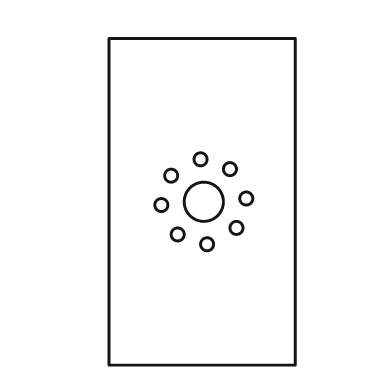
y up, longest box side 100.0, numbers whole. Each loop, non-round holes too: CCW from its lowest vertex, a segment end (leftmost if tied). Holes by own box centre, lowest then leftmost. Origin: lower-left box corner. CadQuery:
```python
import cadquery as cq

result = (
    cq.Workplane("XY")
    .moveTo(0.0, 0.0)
    .lineTo(57.0, 0.0)
    .lineTo(57.0, 100.0)
    .lineTo(0.0, 100.0)
    .close()
    .moveTo(30.0, 37.0)
    .circle(2.0)
    .moveTo(21.0, 40.0)
    .circle(2.0)
    .moveTo(39.0, 42.0)
    .circle(2.0)
    .moveTo(16.0, 49.0)
    .circle(2.0)
    .moveTo(29.0, 50.0)
    .circle(6.0)
    .moveTo(42.0, 51.0)
    .circle(2.0)
    .moveTo(19.0, 58.0)
    .circle(2.0)
    .moveTo(37.0, 60.0)
    .circle(2.0)
    .moveTo(28.0, 63.0)
    .circle(2.0)
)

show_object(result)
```